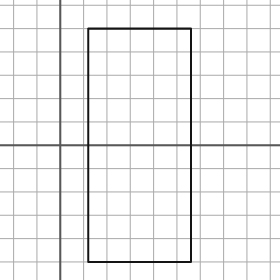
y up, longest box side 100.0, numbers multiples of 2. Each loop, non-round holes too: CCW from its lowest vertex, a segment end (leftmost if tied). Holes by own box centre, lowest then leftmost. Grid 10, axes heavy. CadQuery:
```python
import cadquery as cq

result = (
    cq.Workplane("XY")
    .moveTo(12.0, -50.0)
    .lineTo(56.0, -50.0)
    .lineTo(56.0, 50.0)
    .lineTo(12.0, 50.0)
    .close()
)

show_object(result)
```